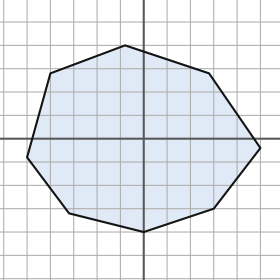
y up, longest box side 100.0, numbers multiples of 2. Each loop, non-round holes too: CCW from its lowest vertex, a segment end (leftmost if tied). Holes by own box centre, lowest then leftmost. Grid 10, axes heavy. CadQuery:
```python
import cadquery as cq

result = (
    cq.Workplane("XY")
    .moveTo(0.0, -40.0)
    .lineTo(30.0, -30.0)
    .lineTo(50.0, -4.0)
    .lineTo(28.0, 28.0)
    .lineTo(-8.0, 40.0)
    .lineTo(-40.0, 28.0)
    .lineTo(-50.0, -8.0)
    .lineTo(-32.0, -32.0)
    .close()
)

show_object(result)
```